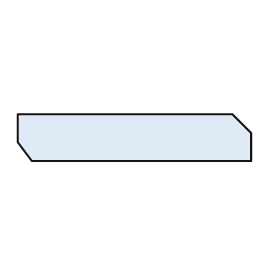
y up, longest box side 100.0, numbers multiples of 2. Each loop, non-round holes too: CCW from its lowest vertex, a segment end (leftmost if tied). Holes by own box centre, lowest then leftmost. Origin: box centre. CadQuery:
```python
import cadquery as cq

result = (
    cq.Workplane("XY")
    .moveTo(-44.0, -10.0)
    .lineTo(50.0, -10.0)
    .lineTo(50.0, 2.0)
    .lineTo(42.0, 10.0)
    .lineTo(-50.0, 10.0)
    .lineTo(-50.0, -2.0)
    .close()
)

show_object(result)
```